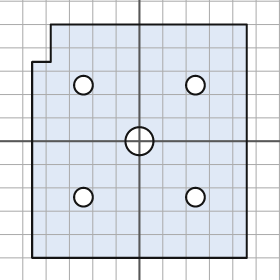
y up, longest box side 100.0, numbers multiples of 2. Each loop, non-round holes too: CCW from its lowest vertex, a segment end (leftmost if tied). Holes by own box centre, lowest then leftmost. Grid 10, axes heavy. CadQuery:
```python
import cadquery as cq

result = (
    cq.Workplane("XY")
    .moveTo(-46.0, -50.0)
    .lineTo(46.0, -50.0)
    .lineTo(46.0, 50.0)
    .lineTo(-38.0, 50.0)
    .lineTo(-38.0, 34.0)
    .lineTo(-46.0, 34.0)
    .close()
    .moveTo(-24.0, -24.0)
    .circle(4.0)
    .moveTo(24.0, -24.0)
    .circle(4.0)
    .moveTo(0.0, 0.0)
    .circle(6.0)
    .moveTo(-24.0, 24.0)
    .circle(4.0)
    .moveTo(24.0, 24.0)
    .circle(4.0)
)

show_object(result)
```